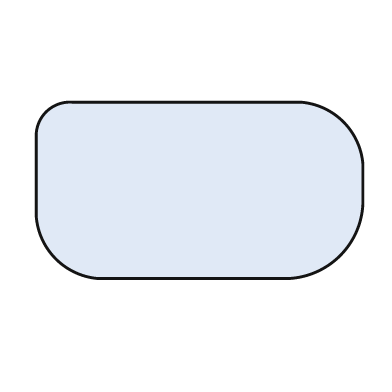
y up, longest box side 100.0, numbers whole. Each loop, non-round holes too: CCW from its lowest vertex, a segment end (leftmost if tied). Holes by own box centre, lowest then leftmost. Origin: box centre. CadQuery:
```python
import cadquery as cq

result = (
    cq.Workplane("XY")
    .moveTo(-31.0, -27.0)
    .lineTo(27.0, -27.0)
    .threePointArc((43.0, -20.0), (50.0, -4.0))
    .lineTo(50.0, 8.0)
    .threePointArc((44.0, 21.0), (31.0, 27.0))
    .lineTo(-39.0, 27.0)
    .threePointArc((-47.0, 24.0), (-50.0, 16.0))
    .lineTo(-50.0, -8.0)
    .threePointArc((-44.0, -21.0), (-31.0, -27.0))
    .close()
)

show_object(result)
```